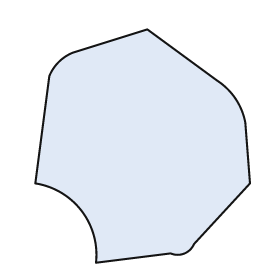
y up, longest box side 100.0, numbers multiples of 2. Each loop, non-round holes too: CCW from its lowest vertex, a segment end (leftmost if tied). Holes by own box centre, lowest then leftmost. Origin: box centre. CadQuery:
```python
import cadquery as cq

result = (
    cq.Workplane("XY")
    .moveTo(-20.0, -50.0)
    .lineTo(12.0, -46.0)
    .threePointArc((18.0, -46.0), (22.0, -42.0))
    .lineTo(46.0, -16.0)
    .lineTo(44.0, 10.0)
    .threePointArc((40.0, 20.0), (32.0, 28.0))
    .lineTo(2.0, 50.0)
    .lineTo(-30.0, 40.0)
    .threePointArc((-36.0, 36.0), (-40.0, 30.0))
    .lineTo(-46.0, -16.0)
    .threePointArc((-26.0, -28.0), (-20.0, -50.0))
    .close()
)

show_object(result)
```